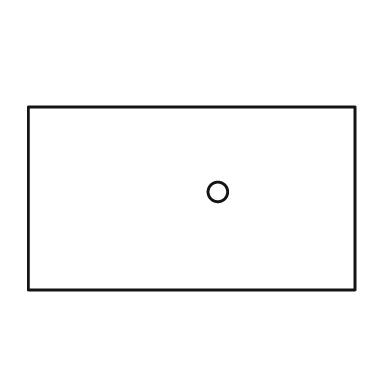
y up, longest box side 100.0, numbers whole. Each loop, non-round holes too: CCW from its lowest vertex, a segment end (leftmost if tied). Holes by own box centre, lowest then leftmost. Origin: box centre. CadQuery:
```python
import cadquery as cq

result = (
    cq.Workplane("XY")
    .moveTo(-50.0, -28.0)
    .lineTo(50.0, -28.0)
    .lineTo(50.0, 28.0)
    .lineTo(-50.0, 28.0)
    .close()
    .moveTo(8.0, 2.0)
    .circle(3.0)
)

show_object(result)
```